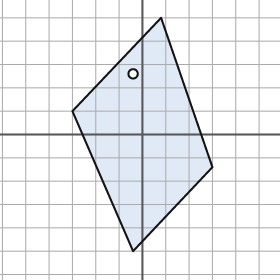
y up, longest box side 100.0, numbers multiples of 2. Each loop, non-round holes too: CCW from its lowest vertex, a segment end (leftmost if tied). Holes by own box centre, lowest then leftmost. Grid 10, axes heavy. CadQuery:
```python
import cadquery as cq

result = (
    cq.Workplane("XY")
    .moveTo(-4.0, -50.0)
    .lineTo(30.0, -14.0)
    .lineTo(8.0, 50.0)
    .lineTo(-30.0, 10.0)
    .close()
    .moveTo(-4.0, 26.0)
    .circle(2.0)
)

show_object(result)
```